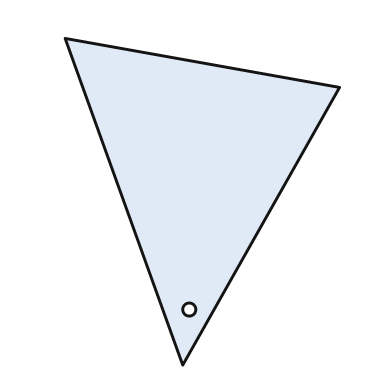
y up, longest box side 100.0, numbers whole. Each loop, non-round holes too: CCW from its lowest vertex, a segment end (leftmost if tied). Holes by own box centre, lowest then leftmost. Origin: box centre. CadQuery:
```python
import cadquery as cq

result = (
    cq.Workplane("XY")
    .moveTo(-6.0, -50.0)
    .lineTo(42.0, 35.0)
    .lineTo(-42.0, 50.0)
    .close()
    .moveTo(-4.0, -33.0)
    .circle(2.0)
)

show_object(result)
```